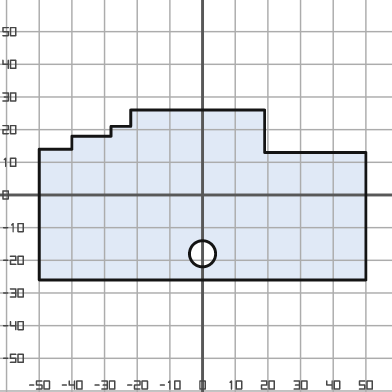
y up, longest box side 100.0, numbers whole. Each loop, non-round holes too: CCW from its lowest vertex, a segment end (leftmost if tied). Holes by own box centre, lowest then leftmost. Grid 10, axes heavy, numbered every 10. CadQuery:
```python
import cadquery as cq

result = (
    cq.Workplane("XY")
    .moveTo(-50.0, -26.0)
    .lineTo(50.0, -26.0)
    .lineTo(50.0, 13.0)
    .lineTo(19.0, 13.0)
    .lineTo(19.0, 26.0)
    .lineTo(-22.0, 26.0)
    .lineTo(-22.0, 21.0)
    .lineTo(-28.0, 21.0)
    .lineTo(-28.0, 18.0)
    .lineTo(-40.0, 18.0)
    .lineTo(-40.0, 14.0)
    .lineTo(-50.0, 14.0)
    .close()
    .moveTo(0.0, -18.0)
    .circle(4.0)
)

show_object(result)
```